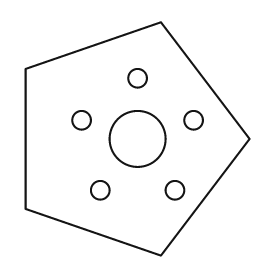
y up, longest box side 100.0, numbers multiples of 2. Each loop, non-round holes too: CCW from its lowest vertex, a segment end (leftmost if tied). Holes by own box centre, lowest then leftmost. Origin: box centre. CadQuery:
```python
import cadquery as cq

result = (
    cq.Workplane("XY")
    .moveTo(10.0, -50.0)
    .lineTo(48.0, 0.0)
    .lineTo(10.0, 50.0)
    .lineTo(-48.0, 30.0)
    .lineTo(-48.0, -30.0)
    .close()
    .moveTo(-16.0, -22.0)
    .circle(4.0)
    .moveTo(16.0, -22.0)
    .circle(4.0)
    .moveTo(0.0, 0.0)
    .circle(12.0)
    .moveTo(-24.0, 8.0)
    .circle(4.0)
    .moveTo(24.0, 8.0)
    .circle(4.0)
    .moveTo(0.0, 26.0)
    .circle(4.0)
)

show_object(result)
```